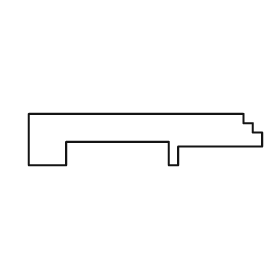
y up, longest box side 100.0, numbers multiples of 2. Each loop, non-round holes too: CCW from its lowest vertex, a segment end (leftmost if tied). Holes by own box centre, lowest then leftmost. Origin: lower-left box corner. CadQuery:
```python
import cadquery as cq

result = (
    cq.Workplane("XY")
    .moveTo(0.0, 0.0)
    .lineTo(16.0, 0.0)
    .lineTo(16.0, 10.0)
    .lineTo(60.0, 10.0)
    .lineTo(60.0, 0.0)
    .lineTo(64.0, 0.0)
    .lineTo(64.0, 8.0)
    .lineTo(100.0, 8.0)
    .lineTo(100.0, 14.0)
    .lineTo(96.0, 14.0)
    .lineTo(96.0, 18.0)
    .lineTo(92.0, 18.0)
    .lineTo(92.0, 22.0)
    .lineTo(0.0, 22.0)
    .close()
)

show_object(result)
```